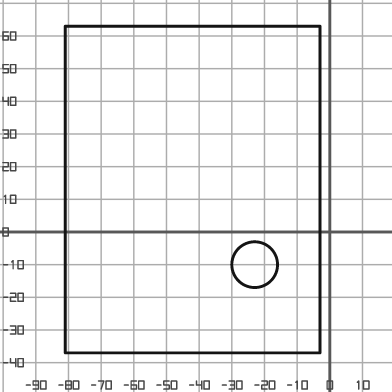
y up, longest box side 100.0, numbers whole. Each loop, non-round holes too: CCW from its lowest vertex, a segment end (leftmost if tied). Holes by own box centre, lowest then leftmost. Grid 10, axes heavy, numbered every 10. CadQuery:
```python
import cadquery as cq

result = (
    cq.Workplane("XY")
    .moveTo(-81.0, -37.0)
    .lineTo(-3.0, -37.0)
    .lineTo(-3.0, 63.0)
    .lineTo(-81.0, 63.0)
    .close()
    .moveTo(-23.0, -10.0)
    .circle(7.0)
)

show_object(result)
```